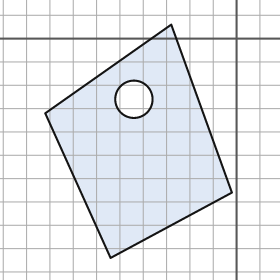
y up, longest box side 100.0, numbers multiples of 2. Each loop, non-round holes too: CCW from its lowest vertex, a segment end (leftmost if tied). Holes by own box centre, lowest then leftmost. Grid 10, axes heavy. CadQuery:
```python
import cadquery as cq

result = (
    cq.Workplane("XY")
    .moveTo(-54.0, -94.0)
    .lineTo(-2.0, -66.0)
    .lineTo(-28.0, 6.0)
    .lineTo(-82.0, -32.0)
    .close()
    .moveTo(-44.0, -26.0)
    .circle(8.0)
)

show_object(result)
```